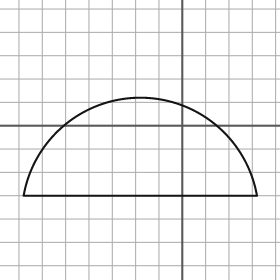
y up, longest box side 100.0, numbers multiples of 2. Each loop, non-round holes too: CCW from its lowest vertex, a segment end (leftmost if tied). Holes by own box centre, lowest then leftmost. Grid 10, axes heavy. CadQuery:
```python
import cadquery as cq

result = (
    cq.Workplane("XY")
    .moveTo(-68.0, -30.0)
    .lineTo(32.0, -30.0)
    .threePointArc((-18.0, 12.0), (-68.0, -30.0))
    .close()
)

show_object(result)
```